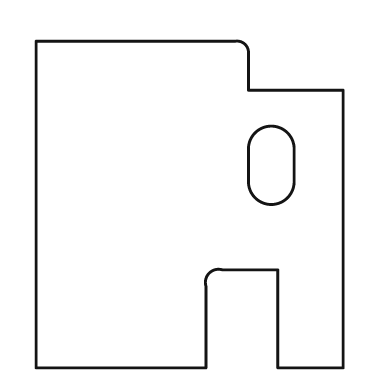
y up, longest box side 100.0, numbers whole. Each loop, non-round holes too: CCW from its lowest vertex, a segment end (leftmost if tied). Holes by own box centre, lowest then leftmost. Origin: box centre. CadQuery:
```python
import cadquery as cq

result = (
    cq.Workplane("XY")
    .moveTo(-47.0, -50.0)
    .lineTo(5.0, -50.0)
    .lineTo(5.0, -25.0)
    .threePointArc((6.0, -21.0), (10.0, -20.0))
    .lineTo(27.0, -20.0)
    .lineTo(27.0, -50.0)
    .lineTo(47.0, -50.0)
    .lineTo(47.0, 35.0)
    .lineTo(18.0, 35.0)
    .lineTo(18.0, 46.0)
    .threePointArc((17.0, 49.0), (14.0, 50.0))
    .lineTo(-47.0, 50.0)
    .close()
    .moveTo(18.0, 7.0)
    .threePointArc((25.0, 0.0), (32.0, 7.0))
    .lineTo(32.0, 17.0)
    .threePointArc((25.0, 24.0), (18.0, 17.0))
    .close()
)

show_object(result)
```